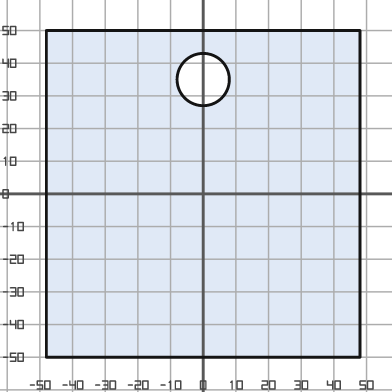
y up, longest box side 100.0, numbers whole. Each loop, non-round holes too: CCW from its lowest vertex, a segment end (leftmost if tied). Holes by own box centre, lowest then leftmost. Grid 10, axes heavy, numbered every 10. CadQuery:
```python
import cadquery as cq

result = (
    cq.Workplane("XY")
    .moveTo(-48.0, -50.0)
    .lineTo(48.0, -50.0)
    .lineTo(48.0, 50.0)
    .lineTo(-48.0, 50.0)
    .close()
    .moveTo(0.0, 35.0)
    .circle(8.0)
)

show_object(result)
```